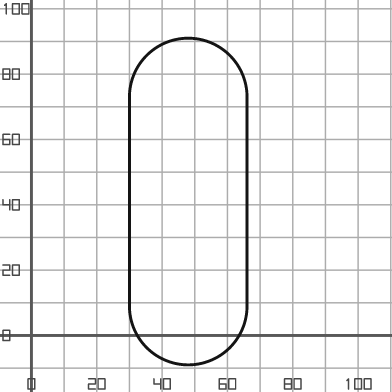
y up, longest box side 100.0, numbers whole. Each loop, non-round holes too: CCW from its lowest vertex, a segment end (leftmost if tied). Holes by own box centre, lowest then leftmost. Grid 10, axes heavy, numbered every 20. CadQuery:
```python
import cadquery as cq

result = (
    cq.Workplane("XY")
    .moveTo(30.0, 9.0)
    .threePointArc((48.0, -9.0), (66.0, 9.0))
    .lineTo(66.0, 73.0)
    .threePointArc((48.0, 91.0), (30.0, 73.0))
    .close()
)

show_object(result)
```